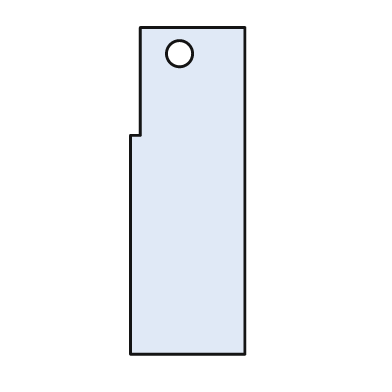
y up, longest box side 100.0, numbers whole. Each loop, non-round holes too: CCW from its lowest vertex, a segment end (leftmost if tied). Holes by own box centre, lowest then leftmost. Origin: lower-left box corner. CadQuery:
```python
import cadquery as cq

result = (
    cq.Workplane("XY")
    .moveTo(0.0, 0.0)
    .lineTo(35.0, 0.0)
    .lineTo(35.0, 100.0)
    .lineTo(3.0, 100.0)
    .lineTo(3.0, 67.0)
    .lineTo(0.0, 67.0)
    .close()
    .moveTo(15.0, 92.0)
    .circle(4.0)
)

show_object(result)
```